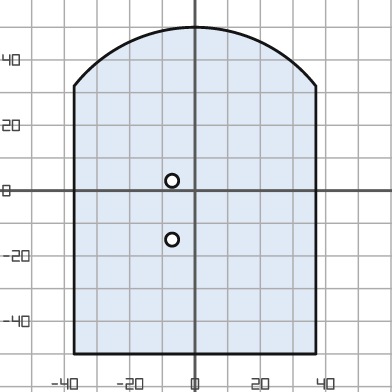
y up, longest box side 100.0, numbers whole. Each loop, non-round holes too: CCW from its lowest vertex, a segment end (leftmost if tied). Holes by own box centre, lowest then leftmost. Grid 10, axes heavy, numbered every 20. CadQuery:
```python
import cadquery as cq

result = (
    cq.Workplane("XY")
    .moveTo(-37.0, -50.0)
    .lineTo(37.0, -50.0)
    .lineTo(37.0, 32.0)
    .threePointArc((0.0, 50.0), (-37.0, 32.0))
    .close()
    .moveTo(-7.0, -15.0)
    .circle(2.0)
    .moveTo(-7.0, 3.0)
    .circle(2.0)
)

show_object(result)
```